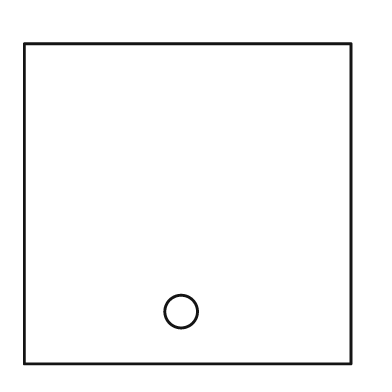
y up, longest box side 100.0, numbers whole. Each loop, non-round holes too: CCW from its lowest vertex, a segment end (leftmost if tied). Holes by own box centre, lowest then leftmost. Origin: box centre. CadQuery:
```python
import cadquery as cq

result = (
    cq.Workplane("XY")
    .moveTo(-50.0, -49.0)
    .lineTo(50.0, -49.0)
    .lineTo(50.0, 49.0)
    .lineTo(-50.0, 49.0)
    .close()
    .moveTo(-2.0, -33.0)
    .circle(5.0)
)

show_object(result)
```